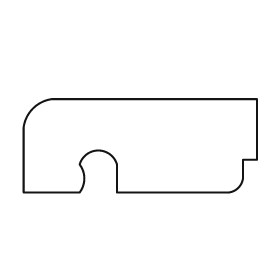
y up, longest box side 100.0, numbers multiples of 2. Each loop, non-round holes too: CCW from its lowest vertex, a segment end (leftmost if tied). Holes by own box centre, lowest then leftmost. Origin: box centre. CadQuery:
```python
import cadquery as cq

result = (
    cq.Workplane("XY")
    .moveTo(-50.0, -20.0)
    .lineTo(-26.0, -20.0)
    .threePointArc((-24.0, -14.0), (-26.0, -8.0))
    .threePointArc((-18.0, -2.0), (-10.0, -8.0))
    .lineTo(-10.0, -20.0)
    .lineTo(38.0, -20.0)
    .threePointArc((42.0, -18.0), (44.0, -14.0))
    .lineTo(44.0, -6.0)
    .lineTo(50.0, -6.0)
    .lineTo(50.0, 20.0)
    .lineTo(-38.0, 20.0)
    .threePointArc((-46.0, 16.0), (-50.0, 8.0))
    .close()
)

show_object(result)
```